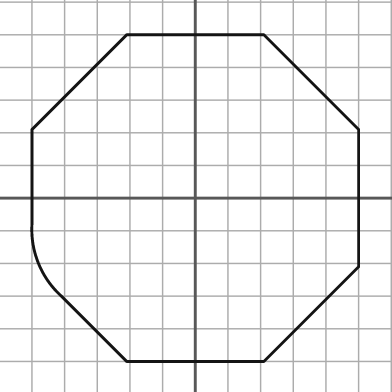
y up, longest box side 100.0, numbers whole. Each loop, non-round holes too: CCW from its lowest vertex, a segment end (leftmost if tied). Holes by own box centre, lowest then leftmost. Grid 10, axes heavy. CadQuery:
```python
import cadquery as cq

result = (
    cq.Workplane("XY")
    .moveTo(-21.0, -50.0)
    .lineTo(21.0, -50.0)
    .lineTo(50.0, -21.0)
    .lineTo(50.0, 21.0)
    .lineTo(21.0, 50.0)
    .lineTo(-21.0, 50.0)
    .lineTo(-50.0, 21.0)
    .lineTo(-50.0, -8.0)
    .threePointArc((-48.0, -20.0), (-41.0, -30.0))
    .close()
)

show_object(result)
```